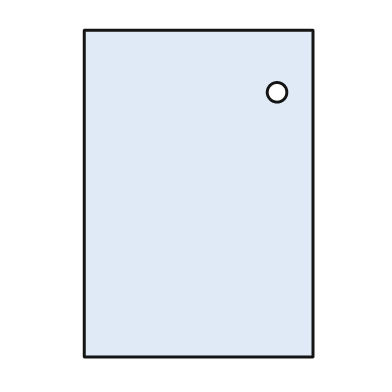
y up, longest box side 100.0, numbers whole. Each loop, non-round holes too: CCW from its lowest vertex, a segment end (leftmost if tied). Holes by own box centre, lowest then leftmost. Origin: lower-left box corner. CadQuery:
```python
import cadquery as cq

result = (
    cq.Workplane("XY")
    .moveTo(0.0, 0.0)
    .lineTo(70.0, 0.0)
    .lineTo(70.0, 100.0)
    .lineTo(0.0, 100.0)
    .close()
    .moveTo(59.0, 81.0)
    .circle(3.0)
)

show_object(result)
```